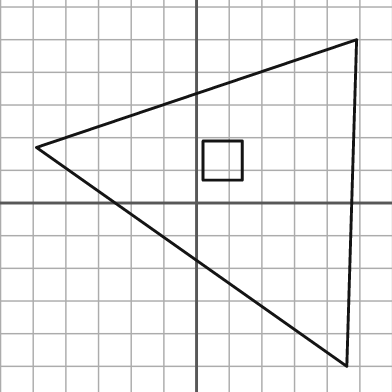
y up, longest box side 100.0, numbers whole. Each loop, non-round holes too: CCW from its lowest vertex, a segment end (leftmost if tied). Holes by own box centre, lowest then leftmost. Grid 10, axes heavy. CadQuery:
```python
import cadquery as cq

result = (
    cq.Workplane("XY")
    .moveTo(46.0, -50.0)
    .lineTo(49.0, 50.0)
    .lineTo(-49.0, 17.0)
    .close()
    .moveTo(2.0, 7.0)
    .lineTo(14.0, 7.0)
    .lineTo(14.0, 19.0)
    .lineTo(2.0, 19.0)
    .close()
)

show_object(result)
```